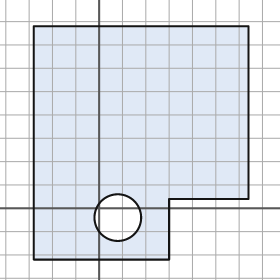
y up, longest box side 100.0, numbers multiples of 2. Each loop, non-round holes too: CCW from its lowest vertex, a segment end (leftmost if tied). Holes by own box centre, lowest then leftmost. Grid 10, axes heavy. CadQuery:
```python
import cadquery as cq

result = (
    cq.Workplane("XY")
    .moveTo(-28.0, -22.0)
    .lineTo(30.0, -22.0)
    .lineTo(30.0, 4.0)
    .lineTo(64.0, 4.0)
    .lineTo(64.0, 78.0)
    .lineTo(-28.0, 78.0)
    .close()
    .moveTo(8.0, -4.0)
    .circle(10.0)
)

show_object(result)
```